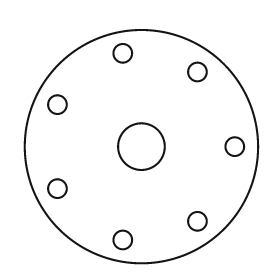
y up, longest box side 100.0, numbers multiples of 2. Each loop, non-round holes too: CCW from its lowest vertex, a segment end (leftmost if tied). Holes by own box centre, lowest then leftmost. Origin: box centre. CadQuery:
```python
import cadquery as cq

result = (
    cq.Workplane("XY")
    .moveTo(0.0, 0.0)
    .circle(50.0)
    .moveTo(-8.0, -40.0)
    .circle(4.0)
    .moveTo(24.0, -32.0)
    .circle(4.0)
    .moveTo(-36.0, -18.0)
    .circle(4.0)
    .moveTo(0.0, 0.0)
    .circle(10.0)
    .moveTo(40.0, 0.0)
    .circle(4.0)
    .moveTo(-36.0, 18.0)
    .circle(4.0)
    .moveTo(24.0, 32.0)
    .circle(4.0)
    .moveTo(-8.0, 40.0)
    .circle(4.0)
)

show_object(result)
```